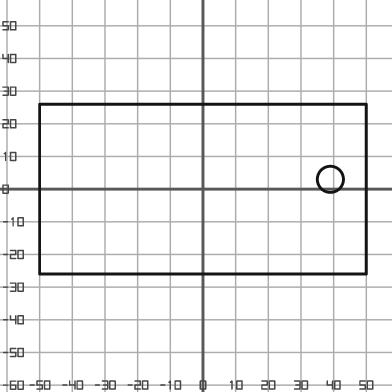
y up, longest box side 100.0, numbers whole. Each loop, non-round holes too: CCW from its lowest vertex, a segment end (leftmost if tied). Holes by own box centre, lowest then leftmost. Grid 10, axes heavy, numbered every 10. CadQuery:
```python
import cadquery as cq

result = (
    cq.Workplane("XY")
    .moveTo(-50.0, -26.0)
    .lineTo(50.0, -26.0)
    .lineTo(50.0, 26.0)
    .lineTo(-50.0, 26.0)
    .close()
    .moveTo(39.0, 3.0)
    .circle(4.0)
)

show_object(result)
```